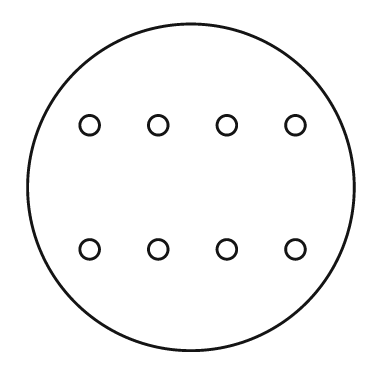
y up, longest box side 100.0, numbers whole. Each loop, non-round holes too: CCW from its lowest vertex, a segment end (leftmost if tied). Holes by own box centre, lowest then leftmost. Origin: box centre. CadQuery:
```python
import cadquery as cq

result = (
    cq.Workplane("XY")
    .moveTo(0.0, 0.0)
    .circle(50.0)
    .moveTo(-31.0, -19.0)
    .circle(3.0)
    .moveTo(-10.0, -19.0)
    .circle(3.0)
    .moveTo(11.0, -19.0)
    .circle(3.0)
    .moveTo(32.0, -19.0)
    .circle(3.0)
    .moveTo(-31.0, 19.0)
    .circle(3.0)
    .moveTo(-10.0, 19.0)
    .circle(3.0)
    .moveTo(11.0, 19.0)
    .circle(3.0)
    .moveTo(32.0, 19.0)
    .circle(3.0)
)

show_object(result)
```